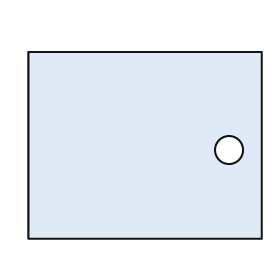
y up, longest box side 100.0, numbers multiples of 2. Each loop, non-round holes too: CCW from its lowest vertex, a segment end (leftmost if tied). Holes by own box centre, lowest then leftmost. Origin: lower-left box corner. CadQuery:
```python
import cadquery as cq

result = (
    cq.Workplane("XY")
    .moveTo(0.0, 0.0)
    .lineTo(100.0, 0.0)
    .lineTo(100.0, 80.0)
    .lineTo(0.0, 80.0)
    .close()
    .moveTo(86.0, 38.0)
    .circle(6.0)
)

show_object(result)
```